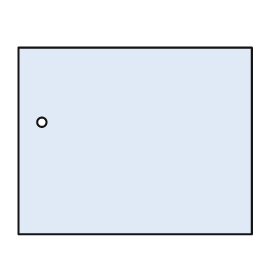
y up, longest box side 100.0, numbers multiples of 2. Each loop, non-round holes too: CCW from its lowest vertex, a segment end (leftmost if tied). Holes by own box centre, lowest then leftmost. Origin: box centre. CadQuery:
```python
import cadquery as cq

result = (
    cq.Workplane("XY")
    .moveTo(-50.0, -40.0)
    .lineTo(50.0, -40.0)
    .lineTo(50.0, 40.0)
    .lineTo(-50.0, 40.0)
    .close()
    .moveTo(-40.0, 8.0)
    .circle(2.0)
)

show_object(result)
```